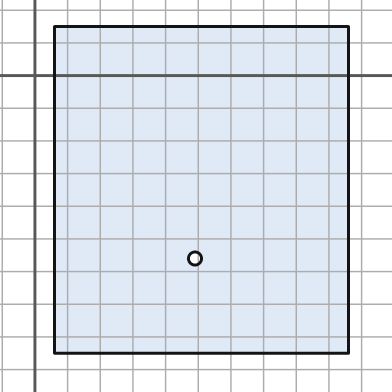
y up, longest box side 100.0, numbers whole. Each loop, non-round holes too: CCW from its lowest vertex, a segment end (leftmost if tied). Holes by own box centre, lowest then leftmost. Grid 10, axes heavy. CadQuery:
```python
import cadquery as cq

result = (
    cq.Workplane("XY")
    .moveTo(6.0, -85.0)
    .lineTo(96.0, -85.0)
    .lineTo(96.0, 15.0)
    .lineTo(6.0, 15.0)
    .close()
    .moveTo(49.0, -56.0)
    .circle(2.0)
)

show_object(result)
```